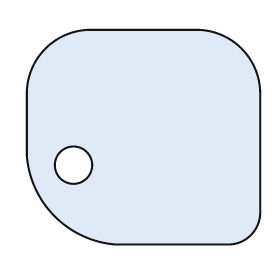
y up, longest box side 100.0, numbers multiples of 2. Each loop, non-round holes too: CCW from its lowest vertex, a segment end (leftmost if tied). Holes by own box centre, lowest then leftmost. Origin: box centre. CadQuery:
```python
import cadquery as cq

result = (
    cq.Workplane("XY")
    .moveTo(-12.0, -46.0)
    .lineTo(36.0, -46.0)
    .threePointArc((46.0, -42.0), (50.0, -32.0))
    .lineTo(50.0, 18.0)
    .threePointArc((42.0, 38.0), (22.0, 46.0))
    .lineTo(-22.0, 46.0)
    .threePointArc((-42.0, 38.0), (-50.0, 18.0))
    .lineTo(-50.0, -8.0)
    .threePointArc((-38.0, -34.0), (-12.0, -46.0))
    .close()
    .moveTo(-30.0, -12.0)
    .circle(8.0)
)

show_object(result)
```